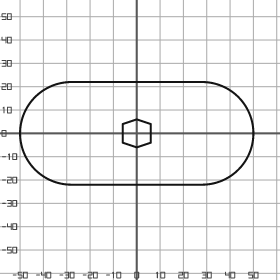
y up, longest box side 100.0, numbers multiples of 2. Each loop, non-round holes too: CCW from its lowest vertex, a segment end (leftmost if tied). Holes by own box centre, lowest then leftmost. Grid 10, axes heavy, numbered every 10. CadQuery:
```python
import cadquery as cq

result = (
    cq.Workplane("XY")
    .moveTo(-28.0, -22.0)
    .lineTo(28.0, -22.0)
    .threePointArc((50.0, 0.0), (28.0, 22.0))
    .lineTo(-28.0, 22.0)
    .threePointArc((-50.0, 0.0), (-28.0, -22.0))
    .close()
    .moveTo(0.0, -6.0)
    .lineTo(6.0, -4.0)
    .lineTo(6.0, 4.0)
    .lineTo(0.0, 6.0)
    .lineTo(-6.0, 4.0)
    .lineTo(-6.0, -4.0)
    .close()
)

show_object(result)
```